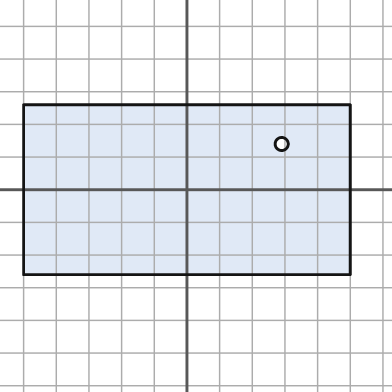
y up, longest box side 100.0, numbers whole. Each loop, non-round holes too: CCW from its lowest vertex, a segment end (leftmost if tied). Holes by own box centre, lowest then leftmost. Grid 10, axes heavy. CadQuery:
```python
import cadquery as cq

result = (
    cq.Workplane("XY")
    .moveTo(-50.0, -26.0)
    .lineTo(50.0, -26.0)
    .lineTo(50.0, 26.0)
    .lineTo(-50.0, 26.0)
    .close()
    .moveTo(29.0, 14.0)
    .circle(2.0)
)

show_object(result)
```